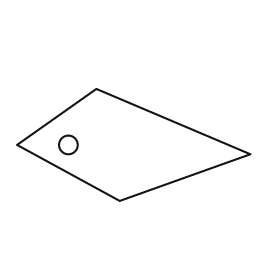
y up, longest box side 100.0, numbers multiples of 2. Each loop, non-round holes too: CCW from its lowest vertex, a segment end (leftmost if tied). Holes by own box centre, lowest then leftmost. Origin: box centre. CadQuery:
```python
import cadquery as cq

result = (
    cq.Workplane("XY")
    .moveTo(-6.0, -24.0)
    .lineTo(50.0, -4.0)
    .lineTo(-16.0, 24.0)
    .lineTo(-50.0, 0.0)
    .close()
    .moveTo(-28.0, 0.0)
    .circle(4.0)
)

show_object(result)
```